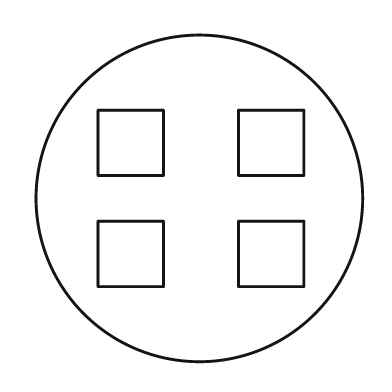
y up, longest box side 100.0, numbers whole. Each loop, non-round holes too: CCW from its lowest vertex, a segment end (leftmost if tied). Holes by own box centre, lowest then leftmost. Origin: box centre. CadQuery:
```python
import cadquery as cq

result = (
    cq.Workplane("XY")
    .moveTo(0.0, 0.0)
    .circle(50.0)
    .moveTo(-31.0, -27.0)
    .lineTo(-11.0, -27.0)
    .lineTo(-11.0, -7.0)
    .lineTo(-31.0, -7.0)
    .close()
    .moveTo(12.0, -27.0)
    .lineTo(32.0, -27.0)
    .lineTo(32.0, -7.0)
    .lineTo(12.0, -7.0)
    .close()
    .moveTo(-31.0, 7.0)
    .lineTo(-11.0, 7.0)
    .lineTo(-11.0, 27.0)
    .lineTo(-31.0, 27.0)
    .close()
    .moveTo(12.0, 7.0)
    .lineTo(32.0, 7.0)
    .lineTo(32.0, 27.0)
    .lineTo(12.0, 27.0)
    .close()
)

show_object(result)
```